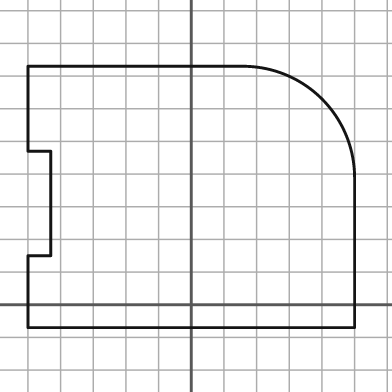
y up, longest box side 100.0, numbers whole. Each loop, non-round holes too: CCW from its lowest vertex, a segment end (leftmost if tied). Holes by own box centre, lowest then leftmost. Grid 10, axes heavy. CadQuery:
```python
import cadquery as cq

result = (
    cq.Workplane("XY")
    .moveTo(-50.0, -7.0)
    .lineTo(50.0, -7.0)
    .lineTo(50.0, 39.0)
    .threePointArc((40.0, 63.0), (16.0, 73.0))
    .lineTo(-50.0, 73.0)
    .lineTo(-50.0, 47.0)
    .lineTo(-43.0, 47.0)
    .lineTo(-43.0, 15.0)
    .lineTo(-50.0, 15.0)
    .close()
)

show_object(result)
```